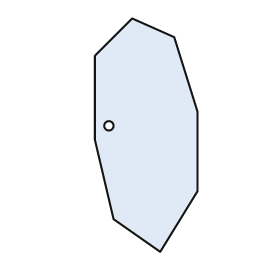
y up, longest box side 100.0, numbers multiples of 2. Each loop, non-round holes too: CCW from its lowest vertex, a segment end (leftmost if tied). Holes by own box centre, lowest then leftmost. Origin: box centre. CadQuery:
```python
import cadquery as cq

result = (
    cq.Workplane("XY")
    .moveTo(6.0, -50.0)
    .lineTo(22.0, -24.0)
    .lineTo(22.0, 10.0)
    .lineTo(12.0, 42.0)
    .lineTo(-6.0, 50.0)
    .lineTo(-22.0, 34.0)
    .lineTo(-22.0, -2.0)
    .lineTo(-14.0, -36.0)
    .close()
    .moveTo(-16.0, 4.0)
    .circle(2.0)
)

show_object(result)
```